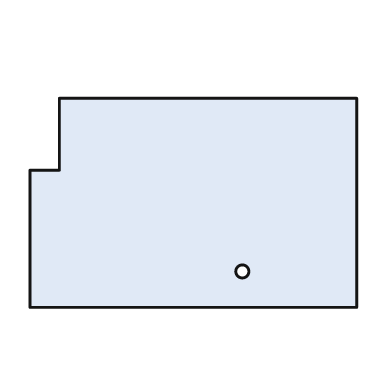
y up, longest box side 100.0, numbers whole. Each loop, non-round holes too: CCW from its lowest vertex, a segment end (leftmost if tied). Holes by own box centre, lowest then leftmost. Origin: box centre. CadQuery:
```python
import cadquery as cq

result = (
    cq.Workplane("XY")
    .moveTo(-50.0, -32.0)
    .lineTo(50.0, -32.0)
    .lineTo(50.0, 32.0)
    .lineTo(-41.0, 32.0)
    .lineTo(-41.0, 10.0)
    .lineTo(-50.0, 10.0)
    .close()
    .moveTo(15.0, -21.0)
    .circle(2.0)
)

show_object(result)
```